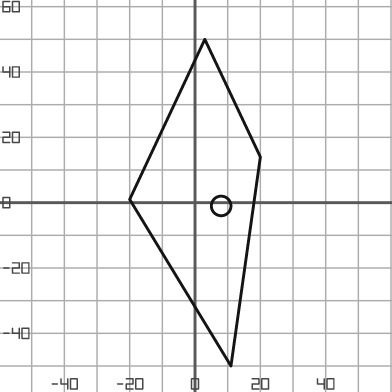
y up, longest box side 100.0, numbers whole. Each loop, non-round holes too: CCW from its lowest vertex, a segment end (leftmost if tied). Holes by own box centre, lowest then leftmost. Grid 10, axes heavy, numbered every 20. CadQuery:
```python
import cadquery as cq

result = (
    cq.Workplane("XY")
    .moveTo(11.0, -50.0)
    .lineTo(20.0, 14.0)
    .lineTo(3.0, 50.0)
    .lineTo(-20.0, 1.0)
    .close()
    .moveTo(8.0, -1.0)
    .circle(3.0)
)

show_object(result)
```